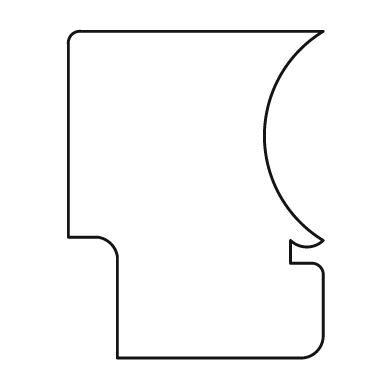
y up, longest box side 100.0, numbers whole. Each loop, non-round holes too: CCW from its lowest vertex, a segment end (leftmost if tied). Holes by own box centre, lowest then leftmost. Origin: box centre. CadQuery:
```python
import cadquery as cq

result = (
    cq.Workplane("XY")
    .moveTo(-24.0, -50.0)
    .lineTo(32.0, -50.0)
    .threePointArc((37.0, -48.0), (39.0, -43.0))
    .lineTo(39.0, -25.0)
    .threePointArc((38.0, -22.0), (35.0, -21.0))
    .lineTo(29.0, -21.0)
    .lineTo(29.0, -14.0)
    .threePointArc((34.0, -16.0), (39.0, -14.0))
    .threePointArc((21.0, 18.0), (39.0, 50.0))
    .lineTo(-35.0, 50.0)
    .threePointArc((-38.0, 49.0), (-39.0, 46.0))
    .lineTo(-39.0, -13.0)
    .lineTo(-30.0, -13.0)
    .threePointArc((-26.0, -15.0), (-24.0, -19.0))
    .close()
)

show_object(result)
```